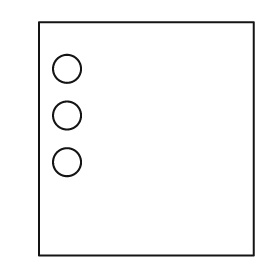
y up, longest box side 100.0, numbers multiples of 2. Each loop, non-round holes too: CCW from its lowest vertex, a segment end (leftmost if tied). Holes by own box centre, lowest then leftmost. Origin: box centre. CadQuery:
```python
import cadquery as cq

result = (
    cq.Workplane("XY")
    .moveTo(-46.0, -50.0)
    .lineTo(46.0, -50.0)
    .lineTo(46.0, 50.0)
    .lineTo(-46.0, 50.0)
    .close()
    .moveTo(-34.0, -10.0)
    .circle(6.0)
    .moveTo(-34.0, 10.0)
    .circle(6.0)
    .moveTo(-34.0, 30.0)
    .circle(6.0)
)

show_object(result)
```